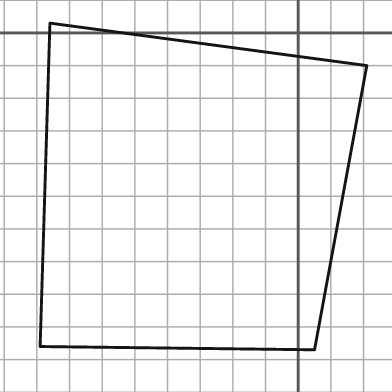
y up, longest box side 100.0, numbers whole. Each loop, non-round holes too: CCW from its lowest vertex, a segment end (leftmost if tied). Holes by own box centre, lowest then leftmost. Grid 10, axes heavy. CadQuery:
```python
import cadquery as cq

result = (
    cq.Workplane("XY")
    .moveTo(5.0, -97.0)
    .lineTo(21.0, -10.0)
    .lineTo(-76.0, 3.0)
    .lineTo(-79.0, -96.0)
    .close()
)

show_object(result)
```